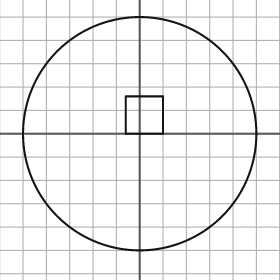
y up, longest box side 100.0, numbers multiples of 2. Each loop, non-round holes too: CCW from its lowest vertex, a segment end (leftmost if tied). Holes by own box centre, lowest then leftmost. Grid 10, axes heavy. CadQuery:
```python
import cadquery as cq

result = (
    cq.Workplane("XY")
    .moveTo(0.0, 0.0)
    .circle(50.0)
    .moveTo(-6.0, 0.0)
    .lineTo(10.0, 0.0)
    .lineTo(10.0, 16.0)
    .lineTo(-6.0, 16.0)
    .close()
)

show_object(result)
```